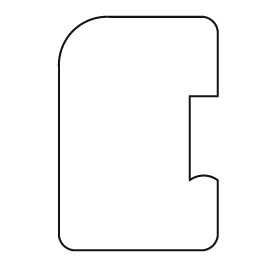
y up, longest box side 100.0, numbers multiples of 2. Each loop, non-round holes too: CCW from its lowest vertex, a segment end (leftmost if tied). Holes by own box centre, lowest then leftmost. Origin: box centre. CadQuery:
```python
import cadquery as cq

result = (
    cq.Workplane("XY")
    .moveTo(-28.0, -50.0)
    .lineTo(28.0, -50.0)
    .threePointArc((32.0, -48.0), (34.0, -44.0))
    .lineTo(34.0, -20.0)
    .threePointArc((28.0, -18.0), (22.0, -20.0))
    .lineTo(22.0, 16.0)
    .lineTo(34.0, 16.0)
    .lineTo(34.0, 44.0)
    .threePointArc((32.0, 48.0), (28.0, 50.0))
    .lineTo(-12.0, 50.0)
    .threePointArc((-28.0, 44.0), (-34.0, 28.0))
    .lineTo(-34.0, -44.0)
    .threePointArc((-32.0, -48.0), (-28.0, -50.0))
    .close()
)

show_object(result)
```